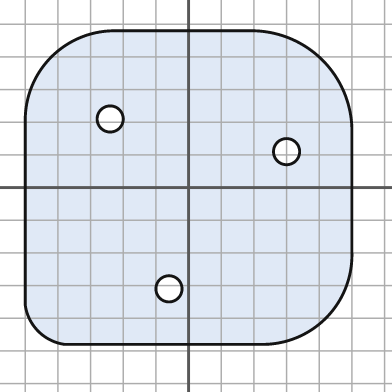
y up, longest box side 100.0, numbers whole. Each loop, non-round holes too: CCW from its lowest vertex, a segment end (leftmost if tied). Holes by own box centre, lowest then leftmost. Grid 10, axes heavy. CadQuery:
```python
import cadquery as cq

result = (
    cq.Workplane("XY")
    .moveTo(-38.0, -48.0)
    .lineTo(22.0, -48.0)
    .threePointArc((42.0, -40.0), (50.0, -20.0))
    .lineTo(50.0, 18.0)
    .threePointArc((41.0, 39.0), (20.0, 48.0))
    .lineTo(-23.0, 48.0)
    .threePointArc((-42.0, 40.0), (-50.0, 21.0))
    .lineTo(-50.0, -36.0)
    .threePointArc((-46.0, -44.0), (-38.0, -48.0))
    .close()
    .moveTo(-6.0, -31.0)
    .circle(4.0)
    .moveTo(30.0, 11.0)
    .circle(4.0)
    .moveTo(-24.0, 21.0)
    .circle(4.0)
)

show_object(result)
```